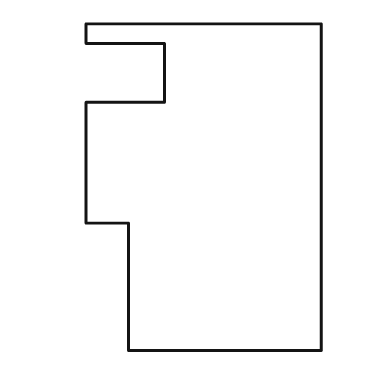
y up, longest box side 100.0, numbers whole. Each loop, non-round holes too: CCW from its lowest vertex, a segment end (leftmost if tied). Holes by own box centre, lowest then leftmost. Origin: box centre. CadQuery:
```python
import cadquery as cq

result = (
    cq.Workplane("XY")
    .moveTo(-23.0, -50.0)
    .lineTo(36.0, -50.0)
    .lineTo(36.0, 50.0)
    .lineTo(-36.0, 50.0)
    .lineTo(-36.0, 44.0)
    .lineTo(-12.0, 44.0)
    .lineTo(-12.0, 26.0)
    .lineTo(-36.0, 26.0)
    .lineTo(-36.0, -11.0)
    .lineTo(-23.0, -11.0)
    .close()
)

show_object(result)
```